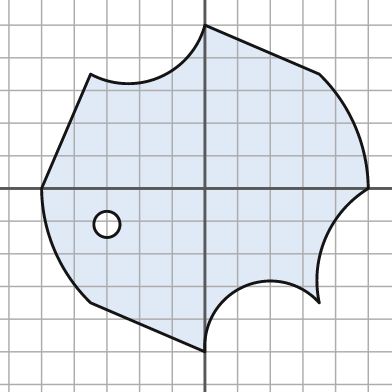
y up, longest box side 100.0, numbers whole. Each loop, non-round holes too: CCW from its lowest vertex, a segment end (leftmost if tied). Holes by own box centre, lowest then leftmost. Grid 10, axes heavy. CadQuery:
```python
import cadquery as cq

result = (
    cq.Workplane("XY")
    .moveTo(0.0, -50.0)
    .threePointArc((12.0, -30.0), (35.0, -35.0))
    .threePointArc((37.0, -15.0), (50.0, 0.0))
    .threePointArc((46.0, 19.0), (35.0, 35.0))
    .lineTo(0.0, 50.0)
    .threePointArc((-14.0, 34.0), (-35.0, 35.0))
    .lineTo(-50.0, 0.0)
    .threePointArc((-46.0, -19.0), (-35.0, -35.0))
    .close()
    .moveTo(-30.0, -11.0)
    .circle(4.0)
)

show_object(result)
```